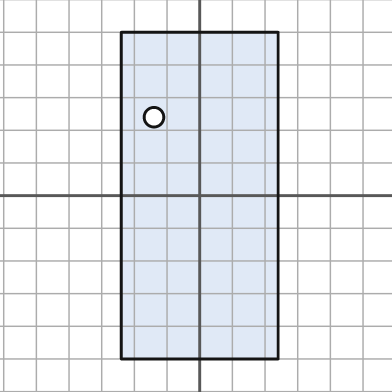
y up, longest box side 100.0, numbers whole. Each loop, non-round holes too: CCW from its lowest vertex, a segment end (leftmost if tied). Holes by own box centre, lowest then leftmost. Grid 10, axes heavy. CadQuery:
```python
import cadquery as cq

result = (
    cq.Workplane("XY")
    .moveTo(-24.0, -50.0)
    .lineTo(24.0, -50.0)
    .lineTo(24.0, 50.0)
    .lineTo(-24.0, 50.0)
    .close()
    .moveTo(-14.0, 24.0)
    .circle(3.0)
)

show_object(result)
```